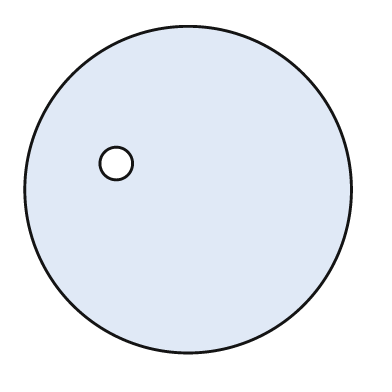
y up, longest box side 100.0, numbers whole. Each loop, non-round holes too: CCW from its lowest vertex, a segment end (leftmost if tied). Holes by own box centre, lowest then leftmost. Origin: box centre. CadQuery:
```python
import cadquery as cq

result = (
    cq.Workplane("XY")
    .moveTo(0.0, 0.0)
    .circle(50.0)
    .moveTo(-22.0, 8.0)
    .circle(5.0)
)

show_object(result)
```